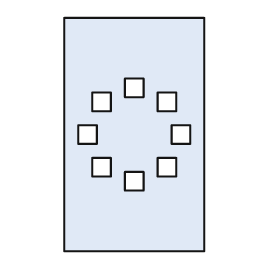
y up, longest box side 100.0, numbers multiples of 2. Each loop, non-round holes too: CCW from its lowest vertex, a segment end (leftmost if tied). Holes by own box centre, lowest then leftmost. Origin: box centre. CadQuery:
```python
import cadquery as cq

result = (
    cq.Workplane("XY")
    .moveTo(-30.0, -50.0)
    .lineTo(30.0, -50.0)
    .lineTo(30.0, 50.0)
    .lineTo(-30.0, 50.0)
    .close()
    .moveTo(-4.0, -24.0)
    .lineTo(4.0, -24.0)
    .lineTo(4.0, -16.0)
    .lineTo(-4.0, -16.0)
    .close()
    .moveTo(-18.0, -18.0)
    .lineTo(-10.0, -18.0)
    .lineTo(-10.0, -10.0)
    .lineTo(-18.0, -10.0)
    .close()
    .moveTo(10.0, -18.0)
    .lineTo(18.0, -18.0)
    .lineTo(18.0, -10.0)
    .lineTo(10.0, -10.0)
    .close()
    .moveTo(-24.0, -4.0)
    .lineTo(-16.0, -4.0)
    .lineTo(-16.0, 4.0)
    .lineTo(-24.0, 4.0)
    .close()
    .moveTo(16.0, -4.0)
    .lineTo(24.0, -4.0)
    .lineTo(24.0, 4.0)
    .lineTo(16.0, 4.0)
    .close()
    .moveTo(-18.0, 10.0)
    .lineTo(-10.0, 10.0)
    .lineTo(-10.0, 18.0)
    .lineTo(-18.0, 18.0)
    .close()
    .moveTo(10.0, 10.0)
    .lineTo(18.0, 10.0)
    .lineTo(18.0, 18.0)
    .lineTo(10.0, 18.0)
    .close()
    .moveTo(-4.0, 16.0)
    .lineTo(4.0, 16.0)
    .lineTo(4.0, 24.0)
    .lineTo(-4.0, 24.0)
    .close()
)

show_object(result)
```